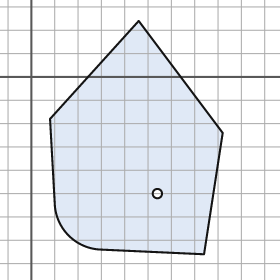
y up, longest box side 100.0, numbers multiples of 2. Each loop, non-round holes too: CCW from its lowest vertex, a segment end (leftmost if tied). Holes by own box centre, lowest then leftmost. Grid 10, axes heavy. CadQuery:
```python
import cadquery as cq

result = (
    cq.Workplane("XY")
    .moveTo(74.0, -76.0)
    .lineTo(82.0, -24.0)
    .lineTo(46.0, 24.0)
    .lineTo(8.0, -18.0)
    .lineTo(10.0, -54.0)
    .threePointArc((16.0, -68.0), (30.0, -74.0))
    .close()
    .moveTo(54.0, -50.0)
    .circle(2.0)
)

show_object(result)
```